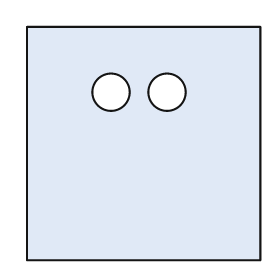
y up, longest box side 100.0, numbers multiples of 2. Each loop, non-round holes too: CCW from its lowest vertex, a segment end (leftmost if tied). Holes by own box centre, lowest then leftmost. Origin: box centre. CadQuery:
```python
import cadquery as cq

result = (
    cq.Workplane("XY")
    .moveTo(-50.0, -50.0)
    .lineTo(50.0, -50.0)
    .lineTo(50.0, 50.0)
    .lineTo(-50.0, 50.0)
    .close()
    .moveTo(-14.0, 22.0)
    .circle(8.0)
    .moveTo(10.0, 22.0)
    .circle(8.0)
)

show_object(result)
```